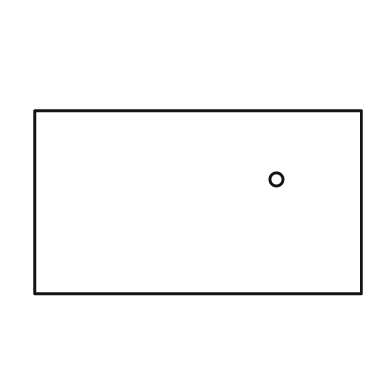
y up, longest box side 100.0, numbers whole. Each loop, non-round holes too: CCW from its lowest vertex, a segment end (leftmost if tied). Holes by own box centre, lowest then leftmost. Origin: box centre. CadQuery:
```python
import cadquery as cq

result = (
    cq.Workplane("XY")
    .moveTo(-50.0, -28.0)
    .lineTo(50.0, -28.0)
    .lineTo(50.0, 28.0)
    .lineTo(-50.0, 28.0)
    .close()
    .moveTo(24.0, 7.0)
    .circle(2.0)
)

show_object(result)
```